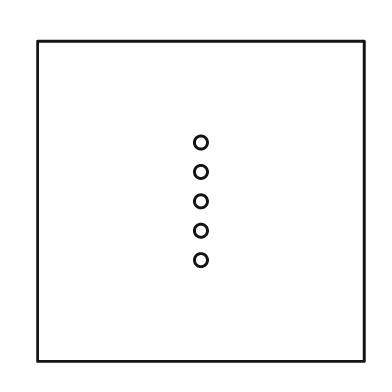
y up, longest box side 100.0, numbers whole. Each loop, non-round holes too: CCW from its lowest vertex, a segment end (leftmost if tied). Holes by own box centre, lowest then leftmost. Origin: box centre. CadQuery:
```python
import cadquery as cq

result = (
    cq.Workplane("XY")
    .moveTo(-50.0, -49.0)
    .lineTo(50.0, -49.0)
    .lineTo(50.0, 49.0)
    .lineTo(-50.0, 49.0)
    .close()
    .moveTo(0.0, -18.0)
    .circle(2.0)
    .moveTo(0.0, -9.0)
    .circle(2.0)
    .moveTo(0.0, 0.0)
    .circle(2.0)
    .moveTo(0.0, 9.0)
    .circle(2.0)
    .moveTo(0.0, 18.0)
    .circle(2.0)
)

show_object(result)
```